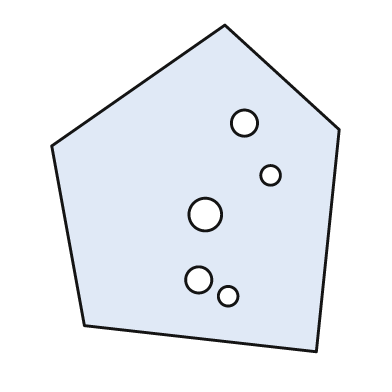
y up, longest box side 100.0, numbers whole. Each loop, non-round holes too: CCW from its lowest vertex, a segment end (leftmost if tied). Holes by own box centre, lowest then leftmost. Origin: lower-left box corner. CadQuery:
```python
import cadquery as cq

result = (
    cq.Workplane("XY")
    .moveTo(81.0, 0.0)
    .lineTo(88.0, 68.0)
    .lineTo(53.0, 100.0)
    .lineTo(0.0, 63.0)
    .lineTo(10.0, 8.0)
    .close()
    .moveTo(54.0, 17.0)
    .circle(3.0)
    .moveTo(45.0, 22.0)
    .circle(4.0)
    .moveTo(47.0, 42.0)
    .circle(5.0)
    .moveTo(67.0, 54.0)
    .circle(3.0)
    .moveTo(59.0, 70.0)
    .circle(4.0)
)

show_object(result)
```